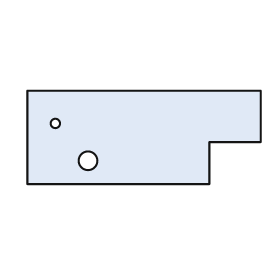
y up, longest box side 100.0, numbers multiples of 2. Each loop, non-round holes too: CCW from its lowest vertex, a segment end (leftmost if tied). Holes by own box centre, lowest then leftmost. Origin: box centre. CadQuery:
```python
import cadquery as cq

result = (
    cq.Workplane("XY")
    .moveTo(-50.0, -20.0)
    .lineTo(28.0, -20.0)
    .lineTo(28.0, -2.0)
    .lineTo(50.0, -2.0)
    .lineTo(50.0, 20.0)
    .lineTo(-50.0, 20.0)
    .close()
    .moveTo(-24.0, -10.0)
    .circle(4.0)
    .moveTo(-38.0, 6.0)
    .circle(2.0)
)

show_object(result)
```